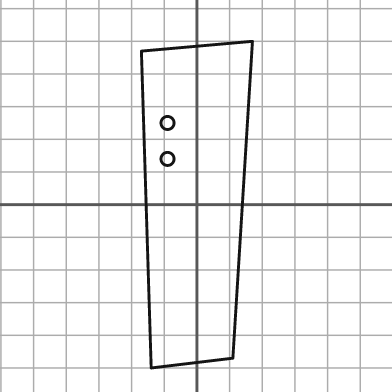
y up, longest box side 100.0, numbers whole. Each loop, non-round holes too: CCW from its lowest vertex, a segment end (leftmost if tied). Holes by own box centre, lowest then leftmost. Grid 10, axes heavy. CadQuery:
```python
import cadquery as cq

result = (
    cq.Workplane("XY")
    .moveTo(-14.0, -50.0)
    .lineTo(11.0, -47.0)
    .lineTo(17.0, 50.0)
    .lineTo(-17.0, 47.0)
    .close()
    .moveTo(-9.0, 14.0)
    .circle(2.0)
    .moveTo(-9.0, 25.0)
    .circle(2.0)
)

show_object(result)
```